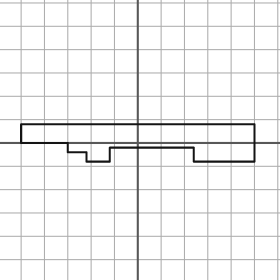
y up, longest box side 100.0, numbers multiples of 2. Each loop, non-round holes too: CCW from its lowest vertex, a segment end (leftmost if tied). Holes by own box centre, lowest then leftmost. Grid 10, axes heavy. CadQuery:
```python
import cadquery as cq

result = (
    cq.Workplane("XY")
    .moveTo(-22.0, -8.0)
    .lineTo(-12.0, -8.0)
    .lineTo(-12.0, -2.0)
    .lineTo(24.0, -2.0)
    .lineTo(24.0, -8.0)
    .lineTo(50.0, -8.0)
    .lineTo(50.0, 8.0)
    .lineTo(-50.0, 8.0)
    .lineTo(-50.0, 0.0)
    .lineTo(-30.0, 0.0)
    .lineTo(-30.0, -4.0)
    .lineTo(-22.0, -4.0)
    .close()
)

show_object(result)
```